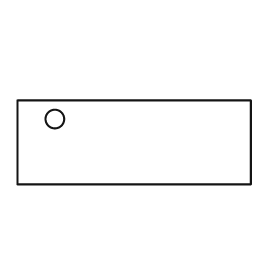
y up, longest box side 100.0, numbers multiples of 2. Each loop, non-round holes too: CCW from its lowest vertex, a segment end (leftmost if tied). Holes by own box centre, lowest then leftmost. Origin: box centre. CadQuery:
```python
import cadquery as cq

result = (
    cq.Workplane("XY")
    .moveTo(-50.0, -18.0)
    .lineTo(50.0, -18.0)
    .lineTo(50.0, 18.0)
    .lineTo(-50.0, 18.0)
    .close()
    .moveTo(-34.0, 10.0)
    .circle(4.0)
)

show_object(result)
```